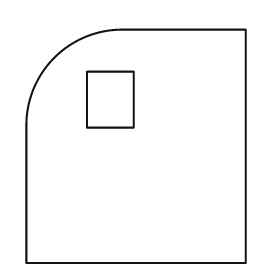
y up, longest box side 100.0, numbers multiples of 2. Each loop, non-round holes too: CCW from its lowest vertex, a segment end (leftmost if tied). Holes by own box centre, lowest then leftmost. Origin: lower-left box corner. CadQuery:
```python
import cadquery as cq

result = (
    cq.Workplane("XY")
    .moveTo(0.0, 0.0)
    .lineTo(94.0, 0.0)
    .lineTo(94.0, 100.0)
    .lineTo(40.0, 100.0)
    .threePointArc((12.0, 88.0), (0.0, 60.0))
    .close()
    .moveTo(26.0, 58.0)
    .lineTo(46.0, 58.0)
    .lineTo(46.0, 82.0)
    .lineTo(26.0, 82.0)
    .close()
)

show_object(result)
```